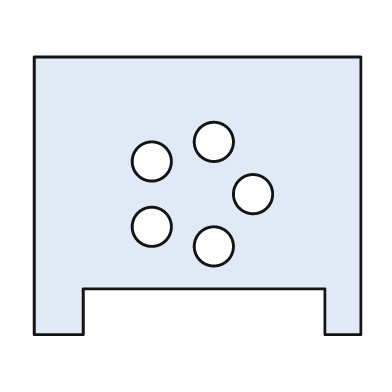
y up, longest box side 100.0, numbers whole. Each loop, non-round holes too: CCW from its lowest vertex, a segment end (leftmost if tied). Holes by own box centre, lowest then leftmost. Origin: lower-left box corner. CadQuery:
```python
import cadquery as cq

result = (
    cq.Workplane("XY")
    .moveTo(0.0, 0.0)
    .lineTo(15.0, 0.0)
    .lineTo(15.0, 14.0)
    .lineTo(89.0, 14.0)
    .lineTo(89.0, 0.0)
    .lineTo(100.0, 0.0)
    .lineTo(100.0, 85.0)
    .lineTo(0.0, 85.0)
    .close()
    .moveTo(55.0, 27.0)
    .circle(6.0)
    .moveTo(36.0, 33.0)
    .circle(6.0)
    .moveTo(67.0, 43.0)
    .circle(6.0)
    .moveTo(36.0, 53.0)
    .circle(6.0)
    .moveTo(55.0, 59.0)
    .circle(6.0)
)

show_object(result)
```